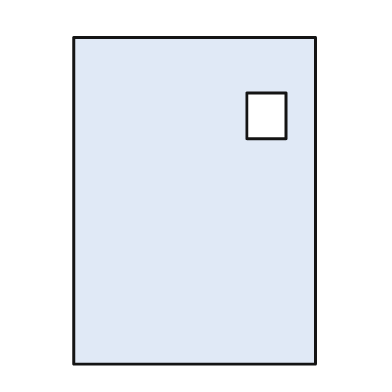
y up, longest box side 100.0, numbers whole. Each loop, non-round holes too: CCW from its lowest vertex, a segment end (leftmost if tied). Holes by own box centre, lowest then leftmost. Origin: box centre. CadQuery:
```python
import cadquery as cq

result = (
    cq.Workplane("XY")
    .moveTo(-37.0, -50.0)
    .lineTo(37.0, -50.0)
    .lineTo(37.0, 50.0)
    .lineTo(-37.0, 50.0)
    .close()
    .moveTo(16.0, 19.0)
    .lineTo(28.0, 19.0)
    .lineTo(28.0, 33.0)
    .lineTo(16.0, 33.0)
    .close()
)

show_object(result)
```